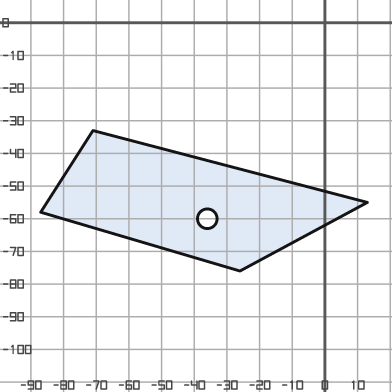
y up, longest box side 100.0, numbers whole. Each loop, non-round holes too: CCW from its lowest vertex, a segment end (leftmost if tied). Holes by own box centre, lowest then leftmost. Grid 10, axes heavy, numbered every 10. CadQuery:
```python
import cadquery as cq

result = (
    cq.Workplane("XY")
    .moveTo(-26.0, -76.0)
    .lineTo(13.0, -55.0)
    .lineTo(-71.0, -33.0)
    .lineTo(-87.0, -58.0)
    .close()
    .moveTo(-36.0, -60.0)
    .circle(3.0)
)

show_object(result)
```